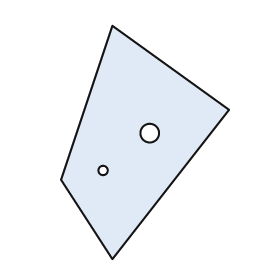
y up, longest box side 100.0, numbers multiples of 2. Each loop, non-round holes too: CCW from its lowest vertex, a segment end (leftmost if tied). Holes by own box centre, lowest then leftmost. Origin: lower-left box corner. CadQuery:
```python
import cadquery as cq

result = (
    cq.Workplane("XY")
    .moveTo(22.0, 0.0)
    .lineTo(72.0, 64.0)
    .lineTo(22.0, 100.0)
    .lineTo(0.0, 34.0)
    .close()
    .moveTo(18.0, 38.0)
    .circle(2.0)
    .moveTo(38.0, 54.0)
    .circle(4.0)
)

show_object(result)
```